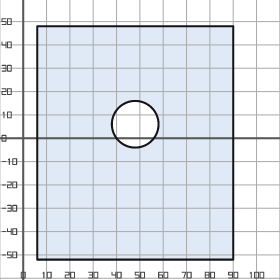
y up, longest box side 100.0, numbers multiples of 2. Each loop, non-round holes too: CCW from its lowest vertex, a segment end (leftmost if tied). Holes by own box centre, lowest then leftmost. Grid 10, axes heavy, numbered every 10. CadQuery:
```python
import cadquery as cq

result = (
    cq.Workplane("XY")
    .moveTo(6.0, -52.0)
    .lineTo(90.0, -52.0)
    .lineTo(90.0, 48.0)
    .lineTo(6.0, 48.0)
    .close()
    .moveTo(48.0, 6.0)
    .circle(10.0)
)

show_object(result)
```